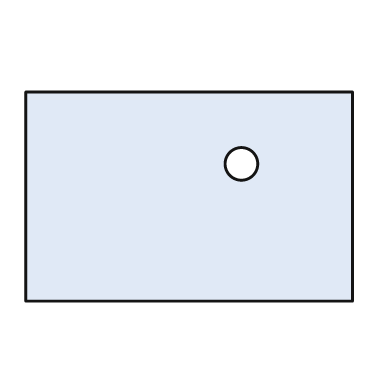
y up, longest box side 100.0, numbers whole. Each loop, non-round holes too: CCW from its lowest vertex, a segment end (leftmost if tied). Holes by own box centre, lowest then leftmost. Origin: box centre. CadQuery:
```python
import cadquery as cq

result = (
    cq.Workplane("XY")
    .moveTo(-50.0, -32.0)
    .lineTo(50.0, -32.0)
    .lineTo(50.0, 32.0)
    .lineTo(-50.0, 32.0)
    .close()
    .moveTo(16.0, 10.0)
    .circle(5.0)
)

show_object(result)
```